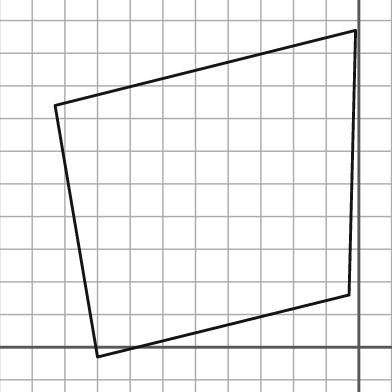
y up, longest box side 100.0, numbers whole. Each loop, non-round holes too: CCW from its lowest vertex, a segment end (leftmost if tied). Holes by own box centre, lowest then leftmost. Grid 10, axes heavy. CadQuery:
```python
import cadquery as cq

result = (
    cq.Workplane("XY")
    .moveTo(-80.0, -3.0)
    .lineTo(-3.0, 16.0)
    .lineTo(-1.0, 97.0)
    .lineTo(-93.0, 74.0)
    .close()
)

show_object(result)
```